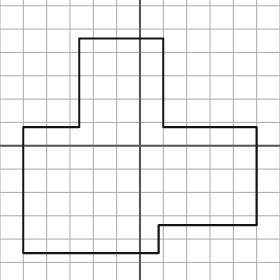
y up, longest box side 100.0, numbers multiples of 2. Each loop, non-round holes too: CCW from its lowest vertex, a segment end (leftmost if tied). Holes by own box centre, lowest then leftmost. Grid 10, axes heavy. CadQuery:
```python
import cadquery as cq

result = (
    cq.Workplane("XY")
    .moveTo(-50.0, -46.0)
    .lineTo(8.0, -46.0)
    .lineTo(8.0, -34.0)
    .lineTo(50.0, -34.0)
    .lineTo(50.0, 8.0)
    .lineTo(10.0, 8.0)
    .lineTo(10.0, 46.0)
    .lineTo(-26.0, 46.0)
    .lineTo(-26.0, 8.0)
    .lineTo(-50.0, 8.0)
    .close()
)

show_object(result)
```